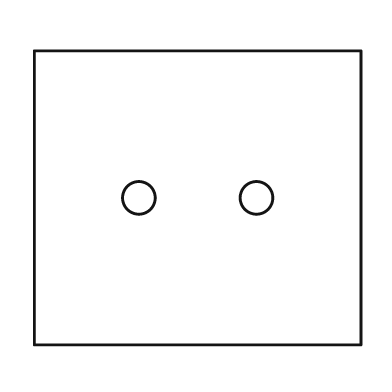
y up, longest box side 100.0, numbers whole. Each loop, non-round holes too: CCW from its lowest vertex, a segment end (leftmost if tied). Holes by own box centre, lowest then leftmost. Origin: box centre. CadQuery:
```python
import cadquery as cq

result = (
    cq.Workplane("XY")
    .moveTo(-50.0, -45.0)
    .lineTo(50.0, -45.0)
    .lineTo(50.0, 45.0)
    .lineTo(-50.0, 45.0)
    .close()
    .moveTo(-18.0, 0.0)
    .circle(5.0)
    .moveTo(18.0, 0.0)
    .circle(5.0)
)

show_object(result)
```